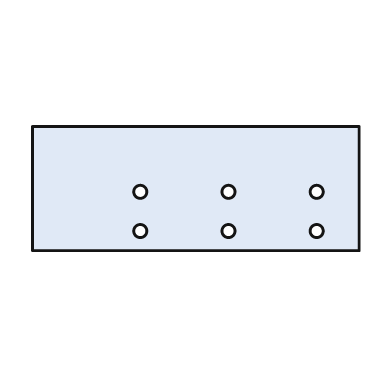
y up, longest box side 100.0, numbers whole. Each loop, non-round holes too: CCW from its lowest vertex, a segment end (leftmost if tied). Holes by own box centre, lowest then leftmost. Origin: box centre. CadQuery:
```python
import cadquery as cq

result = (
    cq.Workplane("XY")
    .moveTo(-50.0, -19.0)
    .lineTo(50.0, -19.0)
    .lineTo(50.0, 19.0)
    .lineTo(-50.0, 19.0)
    .close()
    .moveTo(-17.0, -13.0)
    .circle(2.0)
    .moveTo(10.0, -13.0)
    .circle(2.0)
    .moveTo(37.0, -13.0)
    .circle(2.0)
    .moveTo(-17.0, -1.0)
    .circle(2.0)
    .moveTo(10.0, -1.0)
    .circle(2.0)
    .moveTo(37.0, -1.0)
    .circle(2.0)
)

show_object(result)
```